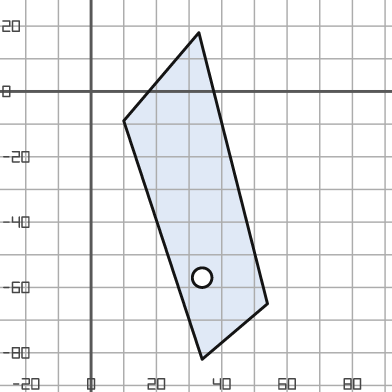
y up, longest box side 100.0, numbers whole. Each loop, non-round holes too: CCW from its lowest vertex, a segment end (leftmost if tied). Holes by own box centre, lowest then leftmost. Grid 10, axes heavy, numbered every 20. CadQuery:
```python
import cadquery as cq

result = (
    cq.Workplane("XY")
    .moveTo(34.0, -82.0)
    .lineTo(54.0, -65.0)
    .lineTo(33.0, 18.0)
    .lineTo(10.0, -9.0)
    .close()
    .moveTo(34.0, -57.0)
    .circle(3.0)
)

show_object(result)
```